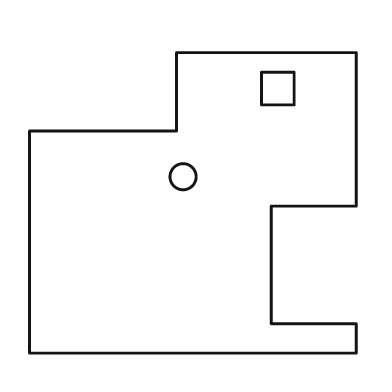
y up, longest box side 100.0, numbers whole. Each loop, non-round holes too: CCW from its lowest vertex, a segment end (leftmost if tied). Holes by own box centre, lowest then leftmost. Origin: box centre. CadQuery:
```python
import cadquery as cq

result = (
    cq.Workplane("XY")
    .moveTo(-50.0, -46.0)
    .lineTo(50.0, -46.0)
    .lineTo(50.0, -37.0)
    .lineTo(24.0, -37.0)
    .lineTo(24.0, -1.0)
    .lineTo(50.0, -1.0)
    .lineTo(50.0, 46.0)
    .lineTo(-5.0, 46.0)
    .lineTo(-5.0, 22.0)
    .lineTo(-50.0, 22.0)
    .close()
    .moveTo(-3.0, 8.0)
    .circle(4.0)
    .moveTo(21.0, 30.0)
    .lineTo(31.0, 30.0)
    .lineTo(31.0, 40.0)
    .lineTo(21.0, 40.0)
    .close()
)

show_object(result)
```